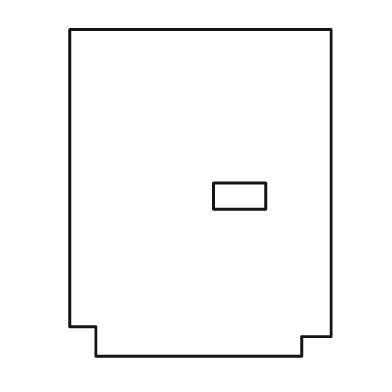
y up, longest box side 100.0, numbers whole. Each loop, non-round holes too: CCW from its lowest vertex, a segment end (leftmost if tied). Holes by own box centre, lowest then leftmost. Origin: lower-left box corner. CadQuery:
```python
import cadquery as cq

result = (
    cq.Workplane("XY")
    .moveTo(8.0, 0.0)
    .lineTo(71.0, 0.0)
    .lineTo(71.0, 6.0)
    .lineTo(80.0, 6.0)
    .lineTo(80.0, 100.0)
    .lineTo(0.0, 100.0)
    .lineTo(0.0, 9.0)
    .lineTo(8.0, 9.0)
    .close()
    .moveTo(44.0, 45.0)
    .lineTo(60.0, 45.0)
    .lineTo(60.0, 53.0)
    .lineTo(44.0, 53.0)
    .close()
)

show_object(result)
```